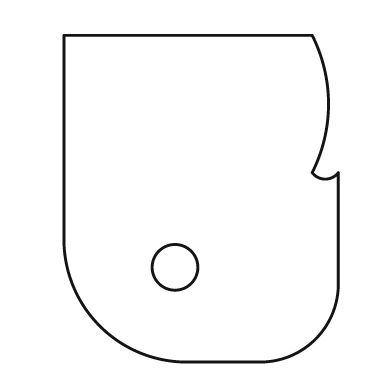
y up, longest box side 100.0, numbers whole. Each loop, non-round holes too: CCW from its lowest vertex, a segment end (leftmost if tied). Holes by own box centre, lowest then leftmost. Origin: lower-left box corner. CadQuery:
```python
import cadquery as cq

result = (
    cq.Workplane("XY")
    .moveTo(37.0, 0.0)
    .lineTo(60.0, 0.0)
    .threePointArc((77.0, 7.0), (84.0, 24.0))
    .lineTo(84.0, 58.0)
    .threePointArc((80.0, 56.0), (76.0, 58.0))
    .threePointArc((81.0, 79.0), (76.0, 100.0))
    .lineTo(0.0, 100.0)
    .lineTo(0.0, 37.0)
    .threePointArc((11.0, 11.0), (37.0, 0.0))
    .close()
    .moveTo(34.0, 29.0)
    .circle(7.0)
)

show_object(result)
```